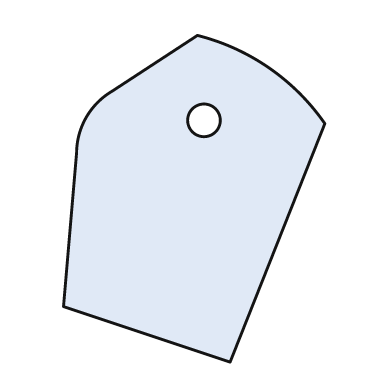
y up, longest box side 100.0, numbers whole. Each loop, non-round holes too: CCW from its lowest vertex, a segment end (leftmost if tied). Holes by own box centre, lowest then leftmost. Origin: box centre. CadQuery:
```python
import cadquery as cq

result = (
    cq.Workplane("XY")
    .moveTo(11.0, -50.0)
    .lineTo(40.0, 23.0)
    .threePointArc((23.0, 40.0), (1.0, 50.0))
    .lineTo(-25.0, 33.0)
    .threePointArc((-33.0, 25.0), (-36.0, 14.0))
    .lineTo(-40.0, -33.0)
    .close()
    .moveTo(3.0, 24.0)
    .circle(5.0)
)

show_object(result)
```